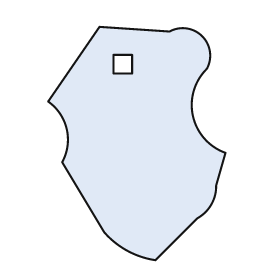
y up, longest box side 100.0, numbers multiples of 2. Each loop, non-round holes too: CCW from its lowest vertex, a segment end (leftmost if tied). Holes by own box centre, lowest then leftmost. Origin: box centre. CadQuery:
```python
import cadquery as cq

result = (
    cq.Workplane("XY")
    .moveTo(8.0, -50.0)
    .lineTo(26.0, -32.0)
    .threePointArc((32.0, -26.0), (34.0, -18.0))
    .lineTo(38.0, -4.0)
    .threePointArc((24.0, 12.0), (30.0, 32.0))
    .threePointArc((28.0, 46.0), (14.0, 48.0))
    .lineTo(-16.0, 50.0)
    .lineTo(-38.0, 18.0)
    .threePointArc((-30.0, 6.0), (-32.0, -8.0))
    .lineTo(-14.0, -38.0)
    .threePointArc((-4.0, -46.0), (8.0, -50.0))
    .close()
    .moveTo(-10.0, 30.0)
    .lineTo(-2.0, 30.0)
    .lineTo(-2.0, 38.0)
    .lineTo(-10.0, 38.0)
    .close()
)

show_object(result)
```